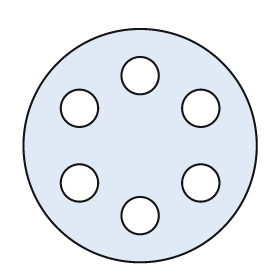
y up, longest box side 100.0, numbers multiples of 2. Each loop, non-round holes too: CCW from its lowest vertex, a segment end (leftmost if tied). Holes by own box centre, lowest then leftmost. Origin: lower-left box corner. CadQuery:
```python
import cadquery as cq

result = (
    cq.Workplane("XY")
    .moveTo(50.0, 50.0)
    .circle(50.0)
    .moveTo(50.0, 20.0)
    .circle(8.0)
    .moveTo(24.0, 34.0)
    .circle(8.0)
    .moveTo(76.0, 34.0)
    .circle(8.0)
    .moveTo(24.0, 66.0)
    .circle(8.0)
    .moveTo(76.0, 66.0)
    .circle(8.0)
    .moveTo(50.0, 80.0)
    .circle(8.0)
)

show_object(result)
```